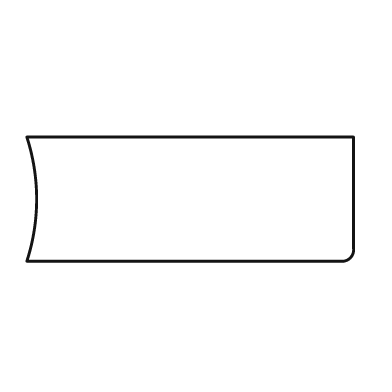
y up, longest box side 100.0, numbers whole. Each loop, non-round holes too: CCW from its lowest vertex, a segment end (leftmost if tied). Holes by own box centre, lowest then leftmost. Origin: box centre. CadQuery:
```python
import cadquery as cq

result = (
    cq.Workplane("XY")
    .moveTo(-50.0, -19.0)
    .lineTo(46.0, -19.0)
    .threePointArc((49.0, -18.0), (50.0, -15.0))
    .lineTo(50.0, 19.0)
    .lineTo(-50.0, 19.0)
    .threePointArc((-47.0, 0.0), (-50.0, -19.0))
    .close()
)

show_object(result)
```